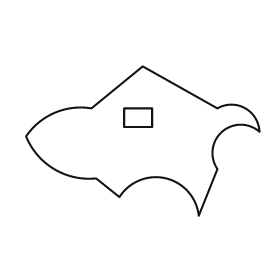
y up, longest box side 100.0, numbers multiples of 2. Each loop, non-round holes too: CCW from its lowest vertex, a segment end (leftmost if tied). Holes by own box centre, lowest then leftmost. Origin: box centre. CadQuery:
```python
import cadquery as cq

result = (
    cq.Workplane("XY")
    .moveTo(24.0, -32.0)
    .lineTo(32.0, -12.0)
    .threePointArc((34.0, 4.0), (50.0, 4.0))
    .threePointArc((44.0, 14.0), (32.0, 14.0))
    .lineTo(0.0, 32.0)
    .lineTo(-22.0, 14.0)
    .threePointArc((-38.0, 12.0), (-50.0, 2.0))
    .threePointArc((-38.0, -12.0), (-20.0, -16.0))
    .lineTo(-10.0, -24.0)
    .threePointArc((10.0, -16.0), (24.0, -32.0))
    .close()
    .moveTo(-8.0, 6.0)
    .lineTo(4.0, 6.0)
    .lineTo(4.0, 14.0)
    .lineTo(-8.0, 14.0)
    .close()
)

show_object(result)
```